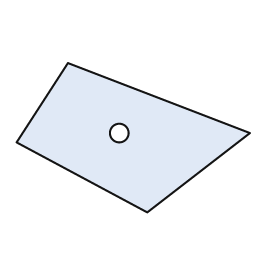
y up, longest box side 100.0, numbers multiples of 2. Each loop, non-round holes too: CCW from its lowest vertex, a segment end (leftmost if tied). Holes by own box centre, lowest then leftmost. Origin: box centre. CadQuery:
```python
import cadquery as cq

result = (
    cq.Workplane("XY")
    .moveTo(6.0, -32.0)
    .lineTo(50.0, 2.0)
    .lineTo(-28.0, 32.0)
    .lineTo(-50.0, -2.0)
    .close()
    .moveTo(-6.0, 2.0)
    .circle(4.0)
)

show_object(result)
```